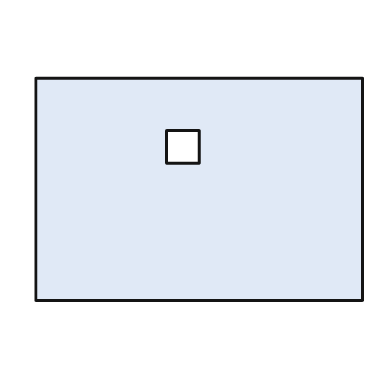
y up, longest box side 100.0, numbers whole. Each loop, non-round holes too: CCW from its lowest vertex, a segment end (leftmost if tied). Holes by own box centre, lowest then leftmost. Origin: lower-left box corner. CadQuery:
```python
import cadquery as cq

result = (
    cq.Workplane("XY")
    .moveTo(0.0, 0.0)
    .lineTo(100.0, 0.0)
    .lineTo(100.0, 68.0)
    .lineTo(0.0, 68.0)
    .close()
    .moveTo(40.0, 42.0)
    .lineTo(50.0, 42.0)
    .lineTo(50.0, 52.0)
    .lineTo(40.0, 52.0)
    .close()
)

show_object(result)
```